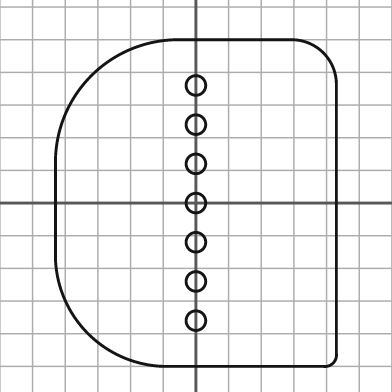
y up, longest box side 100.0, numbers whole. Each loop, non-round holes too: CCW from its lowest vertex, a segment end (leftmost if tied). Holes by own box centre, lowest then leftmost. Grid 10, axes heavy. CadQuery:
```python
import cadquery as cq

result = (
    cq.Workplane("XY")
    .moveTo(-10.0, -50.0)
    .lineTo(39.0, -50.0)
    .threePointArc((42.0, -49.0), (43.0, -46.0))
    .lineTo(43.0, 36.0)
    .threePointArc((39.0, 46.0), (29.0, 50.0))
    .lineTo(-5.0, 50.0)
    .threePointArc((-32.0, 39.0), (-43.0, 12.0))
    .lineTo(-43.0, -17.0)
    .threePointArc((-33.0, -40.0), (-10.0, -50.0))
    .close()
    .moveTo(0.0, -36.0)
    .circle(3.0)
    .moveTo(0.0, -24.0)
    .circle(3.0)
    .moveTo(0.0, -12.0)
    .circle(3.0)
    .moveTo(0.0, 0.0)
    .circle(3.0)
    .moveTo(0.0, 12.0)
    .circle(3.0)
    .moveTo(0.0, 24.0)
    .circle(3.0)
    .moveTo(0.0, 36.0)
    .circle(3.0)
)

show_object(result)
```